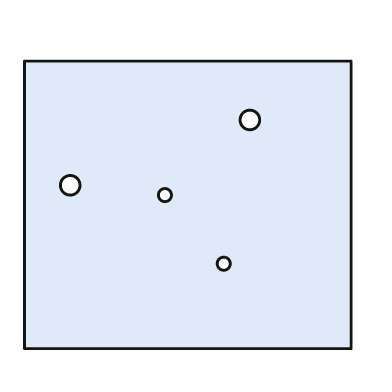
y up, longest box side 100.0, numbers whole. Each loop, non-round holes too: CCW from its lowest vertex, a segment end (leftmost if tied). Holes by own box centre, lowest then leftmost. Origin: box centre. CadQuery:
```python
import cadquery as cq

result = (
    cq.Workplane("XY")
    .moveTo(-50.0, -44.0)
    .lineTo(50.0, -44.0)
    .lineTo(50.0, 44.0)
    .lineTo(-50.0, 44.0)
    .close()
    .moveTo(11.0, -18.0)
    .circle(2.0)
    .moveTo(-7.0, 3.0)
    .circle(2.0)
    .moveTo(-36.0, 6.0)
    .circle(3.0)
    .moveTo(19.0, 26.0)
    .circle(3.0)
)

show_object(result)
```